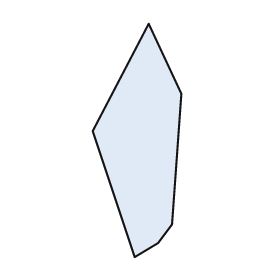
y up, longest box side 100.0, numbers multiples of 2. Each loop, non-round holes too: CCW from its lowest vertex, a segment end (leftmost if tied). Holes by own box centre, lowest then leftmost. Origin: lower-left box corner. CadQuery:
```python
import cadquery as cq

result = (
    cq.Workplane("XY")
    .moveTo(18.0, 0.0)
    .lineTo(28.0, 6.0)
    .lineTo(34.0, 14.0)
    .lineTo(38.0, 70.0)
    .lineTo(24.0, 100.0)
    .lineTo(0.0, 54.0)
    .close()
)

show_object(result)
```